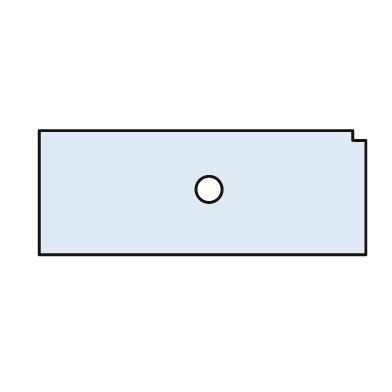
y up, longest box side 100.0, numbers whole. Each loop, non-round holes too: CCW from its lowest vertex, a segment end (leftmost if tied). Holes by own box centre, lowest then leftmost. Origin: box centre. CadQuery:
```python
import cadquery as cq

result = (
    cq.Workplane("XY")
    .moveTo(-50.0, -19.0)
    .lineTo(50.0, -19.0)
    .lineTo(50.0, 16.0)
    .lineTo(46.0, 16.0)
    .lineTo(46.0, 19.0)
    .lineTo(-50.0, 19.0)
    .close()
    .moveTo(2.0, 1.0)
    .circle(4.0)
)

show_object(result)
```